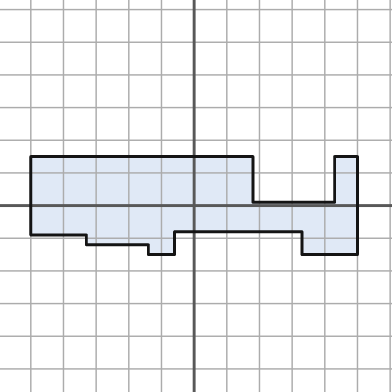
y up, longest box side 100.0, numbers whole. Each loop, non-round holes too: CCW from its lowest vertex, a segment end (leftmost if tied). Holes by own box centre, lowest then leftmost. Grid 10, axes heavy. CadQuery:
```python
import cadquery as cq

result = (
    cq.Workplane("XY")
    .moveTo(-14.0, -15.0)
    .lineTo(-6.0, -15.0)
    .lineTo(-6.0, -8.0)
    .lineTo(33.0, -8.0)
    .lineTo(33.0, -15.0)
    .lineTo(50.0, -15.0)
    .lineTo(50.0, 15.0)
    .lineTo(43.0, 15.0)
    .lineTo(43.0, 1.0)
    .lineTo(18.0, 1.0)
    .lineTo(18.0, 15.0)
    .lineTo(-50.0, 15.0)
    .lineTo(-50.0, -9.0)
    .lineTo(-33.0, -9.0)
    .lineTo(-33.0, -12.0)
    .lineTo(-14.0, -12.0)
    .close()
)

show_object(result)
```